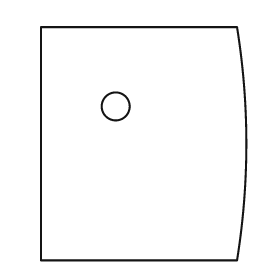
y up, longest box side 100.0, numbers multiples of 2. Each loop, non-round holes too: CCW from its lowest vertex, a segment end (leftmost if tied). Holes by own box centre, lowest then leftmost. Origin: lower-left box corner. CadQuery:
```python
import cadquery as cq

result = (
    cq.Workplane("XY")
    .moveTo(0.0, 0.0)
    .lineTo(84.0, 0.0)
    .threePointArc((88.0, 50.0), (84.0, 100.0))
    .lineTo(0.0, 100.0)
    .close()
    .moveTo(32.0, 66.0)
    .circle(6.0)
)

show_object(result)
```